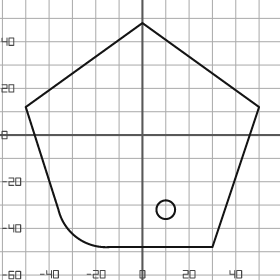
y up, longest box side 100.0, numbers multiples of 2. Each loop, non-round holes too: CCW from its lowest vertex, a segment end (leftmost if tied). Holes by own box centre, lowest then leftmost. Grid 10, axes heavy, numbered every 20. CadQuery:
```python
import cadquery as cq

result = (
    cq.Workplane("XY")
    .moveTo(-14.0, -48.0)
    .lineTo(30.0, -48.0)
    .lineTo(50.0, 12.0)
    .lineTo(0.0, 48.0)
    .lineTo(-50.0, 12.0)
    .lineTo(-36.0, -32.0)
    .threePointArc((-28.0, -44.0), (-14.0, -48.0))
    .close()
    .moveTo(10.0, -32.0)
    .circle(4.0)
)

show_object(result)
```